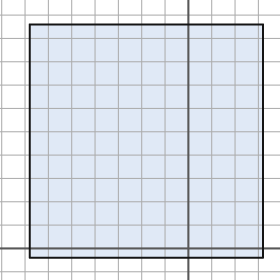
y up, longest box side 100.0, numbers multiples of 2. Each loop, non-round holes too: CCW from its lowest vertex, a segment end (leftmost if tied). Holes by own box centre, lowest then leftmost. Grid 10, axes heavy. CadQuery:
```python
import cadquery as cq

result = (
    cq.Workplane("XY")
    .moveTo(-68.0, -4.0)
    .lineTo(32.0, -4.0)
    .lineTo(32.0, 96.0)
    .lineTo(-68.0, 96.0)
    .close()
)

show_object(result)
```